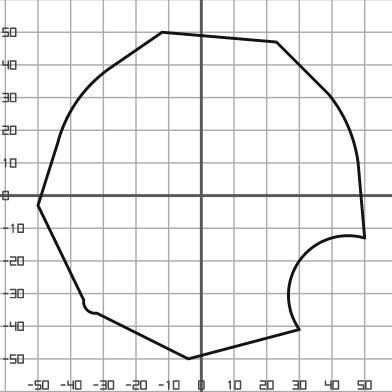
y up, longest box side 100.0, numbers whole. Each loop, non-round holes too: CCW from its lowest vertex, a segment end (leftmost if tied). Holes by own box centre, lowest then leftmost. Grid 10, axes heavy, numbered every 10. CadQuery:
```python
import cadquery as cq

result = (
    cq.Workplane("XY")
    .moveTo(-4.0, -50.0)
    .lineTo(30.0, -41.0)
    .threePointArc((30.0, -20.0), (50.0, -13.0))
    .lineTo(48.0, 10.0)
    .threePointArc((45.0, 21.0), (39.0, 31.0))
    .lineTo(23.0, 47.0)
    .lineTo(-12.0, 50.0)
    .lineTo(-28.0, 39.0)
    .threePointArc((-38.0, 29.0), (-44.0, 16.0))
    .lineTo(-50.0, -3.0)
    .lineTo(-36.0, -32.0)
    .threePointArc((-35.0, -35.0), (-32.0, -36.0))
    .close()
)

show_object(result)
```